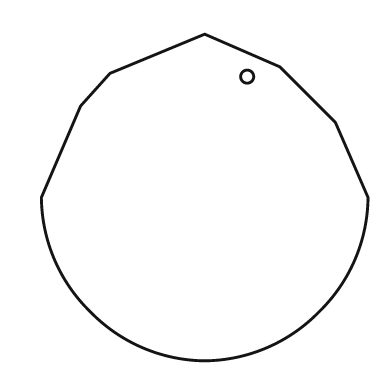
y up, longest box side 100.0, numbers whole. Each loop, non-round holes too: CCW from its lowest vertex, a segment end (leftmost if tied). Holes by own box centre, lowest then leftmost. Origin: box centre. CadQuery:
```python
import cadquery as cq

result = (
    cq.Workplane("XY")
    .moveTo(0.0, -50.0)
    .threePointArc((19.0, -46.0), (35.0, -35.0))
    .threePointArc((46.0, -19.0), (50.0, 0.0))
    .lineTo(40.0, 23.0)
    .lineTo(23.0, 40.0)
    .lineTo(0.0, 50.0)
    .lineTo(-29.0, 38.0)
    .lineTo(-38.0, 28.0)
    .lineTo(-50.0, 0.0)
    .threePointArc((-46.0, -19.0), (-35.0, -35.0))
    .threePointArc((-19.0, -46.0), (0.0, -50.0))
    .close()
    .moveTo(13.0, 37.0)
    .circle(2.0)
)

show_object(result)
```